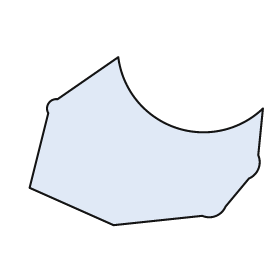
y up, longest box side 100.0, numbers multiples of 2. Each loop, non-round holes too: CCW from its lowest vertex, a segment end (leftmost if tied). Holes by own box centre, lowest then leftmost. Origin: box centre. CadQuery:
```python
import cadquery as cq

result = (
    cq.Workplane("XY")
    .moveTo(-14.0, -36.0)
    .lineTo(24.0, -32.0)
    .threePointArc((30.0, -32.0), (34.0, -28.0))
    .lineTo(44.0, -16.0)
    .threePointArc((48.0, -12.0), (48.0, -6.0))
    .lineTo(50.0, 14.0)
    .threePointArc((12.0, 6.0), (-12.0, 36.0))
    .lineTo(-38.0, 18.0)
    .threePointArc((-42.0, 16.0), (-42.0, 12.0))
    .lineTo(-50.0, -20.0)
    .close()
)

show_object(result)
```